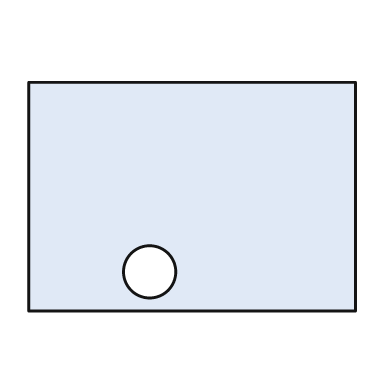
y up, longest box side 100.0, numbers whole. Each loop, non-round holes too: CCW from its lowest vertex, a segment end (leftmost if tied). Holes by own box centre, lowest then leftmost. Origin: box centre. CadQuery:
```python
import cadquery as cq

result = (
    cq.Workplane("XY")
    .moveTo(-50.0, -35.0)
    .lineTo(50.0, -35.0)
    .lineTo(50.0, 35.0)
    .lineTo(-50.0, 35.0)
    .close()
    .moveTo(-13.0, -23.0)
    .circle(8.0)
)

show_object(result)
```